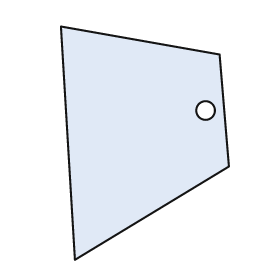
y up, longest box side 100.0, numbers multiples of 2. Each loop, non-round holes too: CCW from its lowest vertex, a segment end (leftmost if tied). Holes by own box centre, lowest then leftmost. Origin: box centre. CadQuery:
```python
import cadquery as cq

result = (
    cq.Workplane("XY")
    .moveTo(-30.0, -50.0)
    .lineTo(36.0, -10.0)
    .lineTo(32.0, 38.0)
    .lineTo(-36.0, 50.0)
    .close()
    .moveTo(26.0, 14.0)
    .circle(4.0)
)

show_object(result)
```